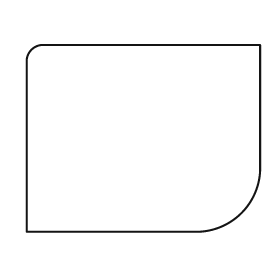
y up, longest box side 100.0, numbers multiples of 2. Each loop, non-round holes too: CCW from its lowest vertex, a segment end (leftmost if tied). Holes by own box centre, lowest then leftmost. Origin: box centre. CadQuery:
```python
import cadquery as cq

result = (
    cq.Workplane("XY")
    .moveTo(-50.0, -40.0)
    .lineTo(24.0, -40.0)
    .threePointArc((42.0, -32.0), (50.0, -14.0))
    .lineTo(50.0, 40.0)
    .lineTo(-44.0, 40.0)
    .threePointArc((-48.0, 38.0), (-50.0, 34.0))
    .close()
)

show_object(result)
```